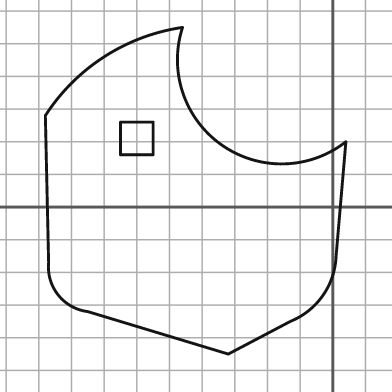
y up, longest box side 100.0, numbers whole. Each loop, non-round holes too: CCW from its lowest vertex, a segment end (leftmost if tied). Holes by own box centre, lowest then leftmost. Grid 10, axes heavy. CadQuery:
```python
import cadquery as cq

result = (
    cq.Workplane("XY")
    .moveTo(-32.0, -45.0)
    .lineTo(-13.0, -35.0)
    .threePointArc((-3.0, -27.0), (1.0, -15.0))
    .lineTo(4.0, 20.0)
    .threePointArc((-34.0, 19.0), (-46.0, 55.0))
    .threePointArc((-70.0, 46.0), (-88.0, 28.0))
    .lineTo(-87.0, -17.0)
    .threePointArc((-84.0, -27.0), (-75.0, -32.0))
    .close()
    .moveTo(-65.0, 16.0)
    .lineTo(-55.0, 16.0)
    .lineTo(-55.0, 26.0)
    .lineTo(-65.0, 26.0)
    .close()
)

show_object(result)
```